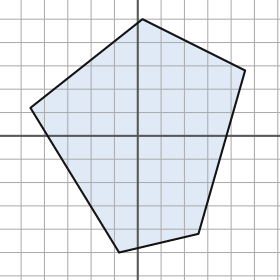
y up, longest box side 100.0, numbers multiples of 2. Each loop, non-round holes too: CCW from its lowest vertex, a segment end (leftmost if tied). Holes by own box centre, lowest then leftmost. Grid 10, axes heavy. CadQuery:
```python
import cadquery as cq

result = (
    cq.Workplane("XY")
    .moveTo(-8.0, -50.0)
    .lineTo(26.0, -42.0)
    .lineTo(46.0, 28.0)
    .lineTo(2.0, 50.0)
    .lineTo(-46.0, 12.0)
    .close()
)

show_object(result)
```